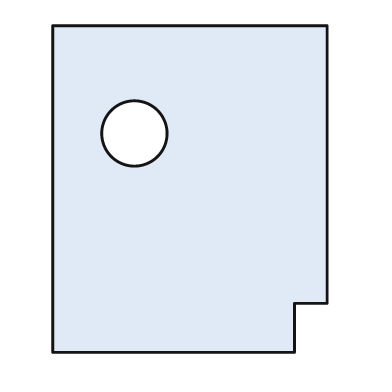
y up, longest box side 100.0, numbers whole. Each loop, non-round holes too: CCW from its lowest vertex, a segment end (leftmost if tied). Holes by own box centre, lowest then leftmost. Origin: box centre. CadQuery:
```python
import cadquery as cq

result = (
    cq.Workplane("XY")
    .moveTo(-42.0, -50.0)
    .lineTo(32.0, -50.0)
    .lineTo(32.0, -35.0)
    .lineTo(42.0, -35.0)
    .lineTo(42.0, 50.0)
    .lineTo(-42.0, 50.0)
    .close()
    .moveTo(-17.0, 17.0)
    .circle(10.0)
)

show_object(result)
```